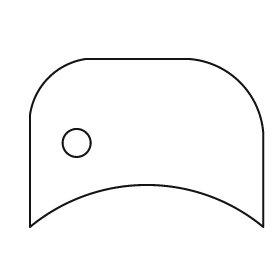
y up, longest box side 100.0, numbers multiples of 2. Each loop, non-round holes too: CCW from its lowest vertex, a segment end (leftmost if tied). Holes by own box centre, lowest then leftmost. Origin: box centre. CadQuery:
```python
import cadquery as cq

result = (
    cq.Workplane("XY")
    .moveTo(-50.0, -36.0)
    .threePointArc((0.0, -18.0), (50.0, -36.0))
    .lineTo(50.0, 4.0)
    .threePointArc((40.0, 26.0), (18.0, 36.0))
    .lineTo(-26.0, 36.0)
    .threePointArc((-42.0, 28.0), (-50.0, 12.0))
    .close()
    .moveTo(-30.0, 0.0)
    .circle(6.0)
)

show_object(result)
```